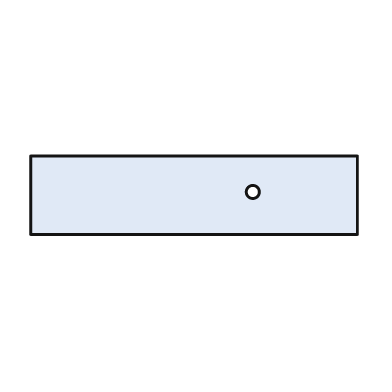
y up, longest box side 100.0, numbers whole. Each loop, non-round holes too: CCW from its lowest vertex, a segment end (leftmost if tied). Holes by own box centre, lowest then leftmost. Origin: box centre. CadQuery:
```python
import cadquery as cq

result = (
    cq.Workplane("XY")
    .moveTo(-50.0, -12.0)
    .lineTo(50.0, -12.0)
    .lineTo(50.0, 12.0)
    .lineTo(-50.0, 12.0)
    .close()
    .moveTo(18.0, 1.0)
    .circle(2.0)
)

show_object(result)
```